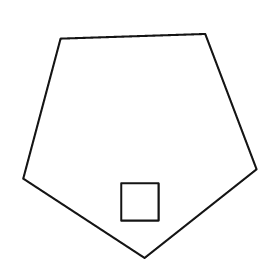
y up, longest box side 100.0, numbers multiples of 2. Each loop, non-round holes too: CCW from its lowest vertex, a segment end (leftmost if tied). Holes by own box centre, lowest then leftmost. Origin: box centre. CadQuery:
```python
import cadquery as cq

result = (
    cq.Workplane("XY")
    .moveTo(2.0, -48.0)
    .lineTo(50.0, -10.0)
    .lineTo(28.0, 48.0)
    .lineTo(-34.0, 46.0)
    .lineTo(-50.0, -14.0)
    .close()
    .moveTo(-8.0, -32.0)
    .lineTo(8.0, -32.0)
    .lineTo(8.0, -16.0)
    .lineTo(-8.0, -16.0)
    .close()
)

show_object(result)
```